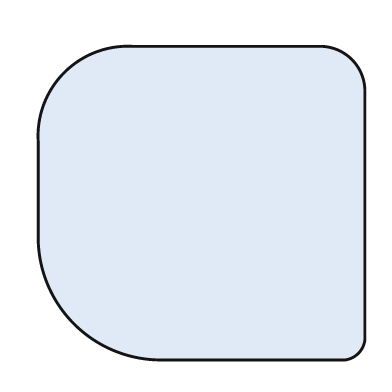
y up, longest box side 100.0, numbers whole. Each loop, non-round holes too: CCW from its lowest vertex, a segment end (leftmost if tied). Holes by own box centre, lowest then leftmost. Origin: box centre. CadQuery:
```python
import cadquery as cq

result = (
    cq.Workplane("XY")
    .moveTo(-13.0, -48.0)
    .lineTo(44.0, -48.0)
    .threePointArc((48.0, -46.0), (50.0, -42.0))
    .lineTo(50.0, 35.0)
    .threePointArc((46.0, 44.0), (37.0, 48.0))
    .lineTo(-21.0, 48.0)
    .threePointArc((-42.0, 40.0), (-50.0, 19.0))
    .lineTo(-50.0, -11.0)
    .threePointArc((-39.0, -37.0), (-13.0, -48.0))
    .close()
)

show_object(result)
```